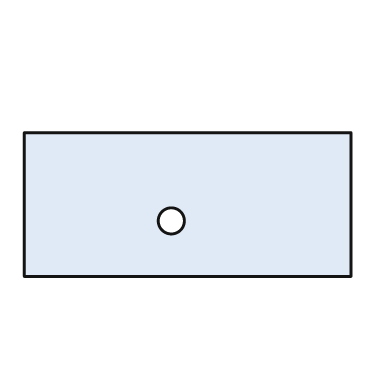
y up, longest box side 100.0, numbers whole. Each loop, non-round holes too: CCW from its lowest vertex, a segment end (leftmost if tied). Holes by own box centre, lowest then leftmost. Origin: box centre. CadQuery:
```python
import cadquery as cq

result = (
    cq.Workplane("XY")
    .moveTo(-50.0, -22.0)
    .lineTo(50.0, -22.0)
    .lineTo(50.0, 22.0)
    .lineTo(-50.0, 22.0)
    .close()
    .moveTo(-5.0, -5.0)
    .circle(4.0)
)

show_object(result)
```